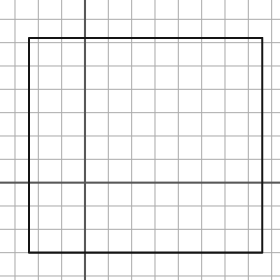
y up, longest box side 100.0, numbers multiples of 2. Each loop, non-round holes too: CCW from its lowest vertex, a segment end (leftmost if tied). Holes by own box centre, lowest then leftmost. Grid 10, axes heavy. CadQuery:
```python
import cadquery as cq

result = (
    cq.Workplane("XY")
    .moveTo(-24.0, -30.0)
    .lineTo(76.0, -30.0)
    .lineTo(76.0, 62.0)
    .lineTo(-24.0, 62.0)
    .close()
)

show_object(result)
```